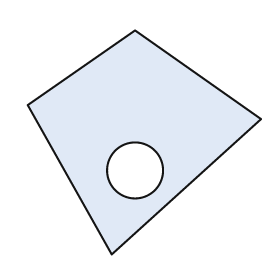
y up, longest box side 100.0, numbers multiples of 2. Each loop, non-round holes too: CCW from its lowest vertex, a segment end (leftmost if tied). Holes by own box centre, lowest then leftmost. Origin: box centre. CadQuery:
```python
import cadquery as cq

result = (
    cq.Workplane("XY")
    .moveTo(-14.0, -48.0)
    .lineTo(50.0, 10.0)
    .lineTo(-4.0, 48.0)
    .lineTo(-50.0, 16.0)
    .close()
    .moveTo(-4.0, -12.0)
    .circle(12.0)
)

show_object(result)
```